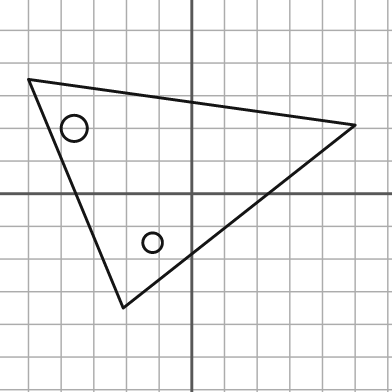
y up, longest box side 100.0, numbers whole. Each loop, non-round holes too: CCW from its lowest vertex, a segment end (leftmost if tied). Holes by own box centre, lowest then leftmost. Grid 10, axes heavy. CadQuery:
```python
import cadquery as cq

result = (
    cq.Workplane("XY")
    .moveTo(-21.0, -35.0)
    .lineTo(50.0, 21.0)
    .lineTo(-50.0, 35.0)
    .close()
    .moveTo(-12.0, -15.0)
    .circle(3.0)
    .moveTo(-36.0, 20.0)
    .circle(4.0)
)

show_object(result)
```